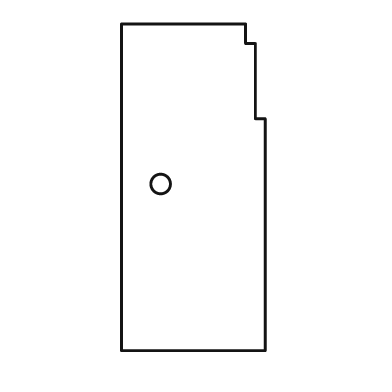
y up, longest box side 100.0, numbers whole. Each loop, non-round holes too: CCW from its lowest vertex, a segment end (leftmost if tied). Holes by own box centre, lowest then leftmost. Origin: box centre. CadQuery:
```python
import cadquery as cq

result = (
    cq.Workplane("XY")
    .moveTo(-22.0, -50.0)
    .lineTo(22.0, -50.0)
    .lineTo(22.0, 21.0)
    .lineTo(19.0, 21.0)
    .lineTo(19.0, 44.0)
    .lineTo(16.0, 44.0)
    .lineTo(16.0, 50.0)
    .lineTo(-22.0, 50.0)
    .close()
    .moveTo(-10.0, 1.0)
    .circle(3.0)
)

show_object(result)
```